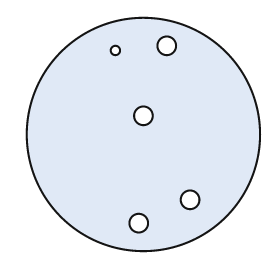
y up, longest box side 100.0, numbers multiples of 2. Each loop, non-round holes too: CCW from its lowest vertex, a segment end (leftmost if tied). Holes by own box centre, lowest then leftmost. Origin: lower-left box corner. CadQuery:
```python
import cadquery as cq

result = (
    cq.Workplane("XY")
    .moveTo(50.0, 50.0)
    .circle(50.0)
    .moveTo(48.0, 12.0)
    .circle(4.0)
    .moveTo(70.0, 22.0)
    .circle(4.0)
    .moveTo(50.0, 58.0)
    .circle(4.0)
    .moveTo(38.0, 86.0)
    .circle(2.0)
    .moveTo(60.0, 88.0)
    .circle(4.0)
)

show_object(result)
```